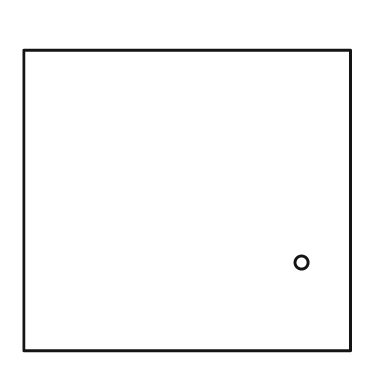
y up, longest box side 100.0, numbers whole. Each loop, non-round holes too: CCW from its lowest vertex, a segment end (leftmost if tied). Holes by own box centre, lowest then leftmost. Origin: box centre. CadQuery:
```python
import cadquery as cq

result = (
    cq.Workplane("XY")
    .moveTo(-50.0, -46.0)
    .lineTo(50.0, -46.0)
    .lineTo(50.0, 46.0)
    .lineTo(-50.0, 46.0)
    .close()
    .moveTo(35.0, -19.0)
    .circle(2.0)
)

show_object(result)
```